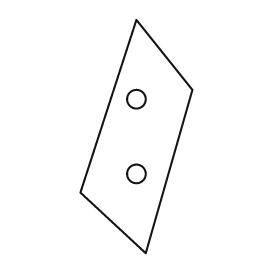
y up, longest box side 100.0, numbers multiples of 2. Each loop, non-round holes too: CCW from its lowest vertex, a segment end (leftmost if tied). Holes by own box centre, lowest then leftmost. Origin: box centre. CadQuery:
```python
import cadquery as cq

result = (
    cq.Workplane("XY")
    .moveTo(4.0, -50.0)
    .lineTo(24.0, 20.0)
    .lineTo(0.0, 50.0)
    .lineTo(-24.0, -24.0)
    .close()
    .moveTo(0.0, -16.0)
    .circle(4.0)
    .moveTo(0.0, 16.0)
    .circle(4.0)
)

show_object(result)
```